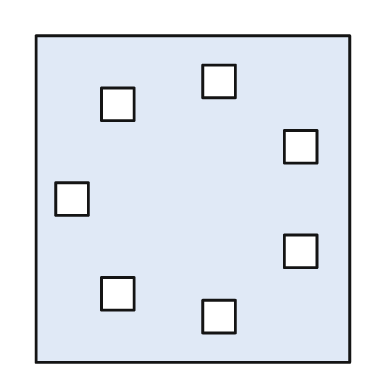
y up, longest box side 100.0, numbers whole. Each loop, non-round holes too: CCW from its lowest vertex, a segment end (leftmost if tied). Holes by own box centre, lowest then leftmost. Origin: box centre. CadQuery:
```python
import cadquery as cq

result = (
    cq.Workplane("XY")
    .moveTo(-48.0, -50.0)
    .lineTo(48.0, -50.0)
    .lineTo(48.0, 50.0)
    .lineTo(-48.0, 50.0)
    .close()
    .moveTo(3.0, -41.0)
    .lineTo(13.0, -41.0)
    .lineTo(13.0, -31.0)
    .lineTo(3.0, -31.0)
    .close()
    .moveTo(-28.0, -34.0)
    .lineTo(-18.0, -34.0)
    .lineTo(-18.0, -24.0)
    .lineTo(-28.0, -24.0)
    .close()
    .moveTo(28.0, -21.0)
    .lineTo(38.0, -21.0)
    .lineTo(38.0, -11.0)
    .lineTo(28.0, -11.0)
    .close()
    .moveTo(-42.0, -5.0)
    .lineTo(-32.0, -5.0)
    .lineTo(-32.0, 5.0)
    .lineTo(-42.0, 5.0)
    .close()
    .moveTo(28.0, 11.0)
    .lineTo(38.0, 11.0)
    .lineTo(38.0, 21.0)
    .lineTo(28.0, 21.0)
    .close()
    .moveTo(-28.0, 24.0)
    .lineTo(-18.0, 24.0)
    .lineTo(-18.0, 34.0)
    .lineTo(-28.0, 34.0)
    .close()
    .moveTo(3.0, 31.0)
    .lineTo(13.0, 31.0)
    .lineTo(13.0, 41.0)
    .lineTo(3.0, 41.0)
    .close()
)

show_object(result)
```